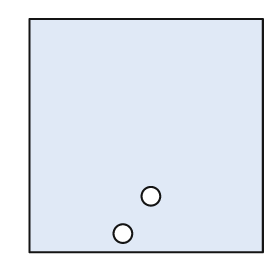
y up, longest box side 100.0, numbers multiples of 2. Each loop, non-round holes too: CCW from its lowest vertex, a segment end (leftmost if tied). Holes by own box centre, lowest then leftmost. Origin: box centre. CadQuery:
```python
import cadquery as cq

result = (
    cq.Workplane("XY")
    .moveTo(-50.0, -50.0)
    .lineTo(50.0, -50.0)
    .lineTo(50.0, 50.0)
    .lineTo(-50.0, 50.0)
    .close()
    .moveTo(-10.0, -42.0)
    .circle(4.0)
    .moveTo(2.0, -26.0)
    .circle(4.0)
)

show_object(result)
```